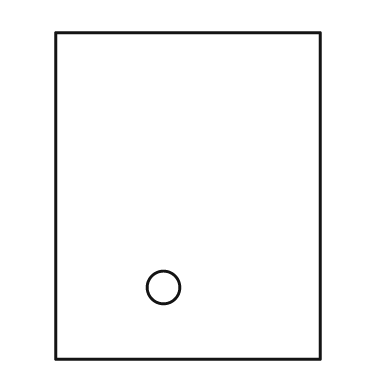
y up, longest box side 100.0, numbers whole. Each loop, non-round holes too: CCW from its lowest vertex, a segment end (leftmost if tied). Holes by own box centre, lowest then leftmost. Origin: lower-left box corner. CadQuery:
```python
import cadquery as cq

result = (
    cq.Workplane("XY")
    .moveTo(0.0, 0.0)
    .lineTo(81.0, 0.0)
    .lineTo(81.0, 100.0)
    .lineTo(0.0, 100.0)
    .close()
    .moveTo(33.0, 22.0)
    .circle(5.0)
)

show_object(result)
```